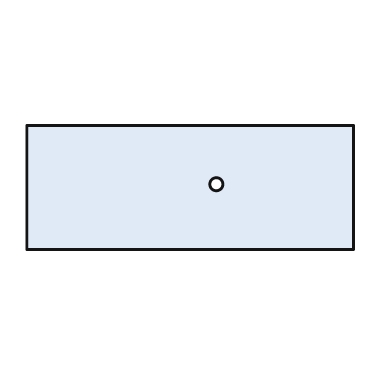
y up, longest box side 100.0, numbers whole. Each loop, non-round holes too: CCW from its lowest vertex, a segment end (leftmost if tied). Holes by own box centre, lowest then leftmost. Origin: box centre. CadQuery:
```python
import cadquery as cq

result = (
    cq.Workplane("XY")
    .moveTo(-50.0, -19.0)
    .lineTo(50.0, -19.0)
    .lineTo(50.0, 19.0)
    .lineTo(-50.0, 19.0)
    .close()
    .moveTo(8.0, 1.0)
    .circle(2.0)
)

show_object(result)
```